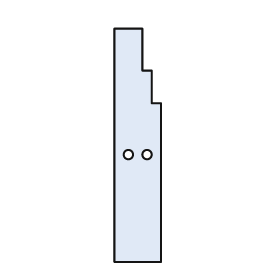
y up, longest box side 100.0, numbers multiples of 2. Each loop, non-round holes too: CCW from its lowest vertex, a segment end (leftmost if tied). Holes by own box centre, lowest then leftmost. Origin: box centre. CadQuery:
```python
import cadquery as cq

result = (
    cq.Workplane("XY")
    .moveTo(-10.0, -50.0)
    .lineTo(10.0, -50.0)
    .lineTo(10.0, 18.0)
    .lineTo(6.0, 18.0)
    .lineTo(6.0, 32.0)
    .lineTo(2.0, 32.0)
    .lineTo(2.0, 50.0)
    .lineTo(-10.0, 50.0)
    .close()
    .moveTo(-4.0, -4.0)
    .circle(2.0)
    .moveTo(4.0, -4.0)
    .circle(2.0)
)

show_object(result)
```